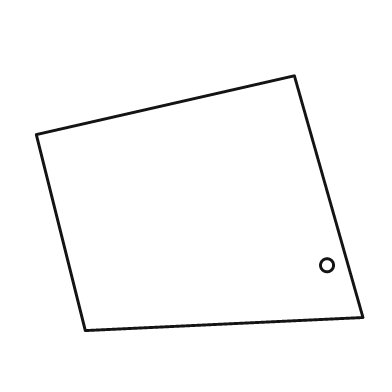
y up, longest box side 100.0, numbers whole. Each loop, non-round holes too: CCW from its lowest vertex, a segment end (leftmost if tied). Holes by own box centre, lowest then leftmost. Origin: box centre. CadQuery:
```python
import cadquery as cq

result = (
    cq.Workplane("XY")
    .moveTo(-35.0, -39.0)
    .lineTo(50.0, -35.0)
    .lineTo(29.0, 39.0)
    .lineTo(-50.0, 21.0)
    .close()
    .moveTo(39.0, -19.0)
    .circle(2.0)
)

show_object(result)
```